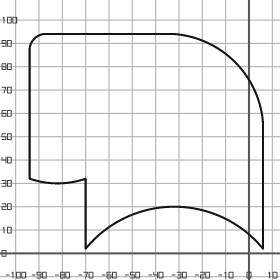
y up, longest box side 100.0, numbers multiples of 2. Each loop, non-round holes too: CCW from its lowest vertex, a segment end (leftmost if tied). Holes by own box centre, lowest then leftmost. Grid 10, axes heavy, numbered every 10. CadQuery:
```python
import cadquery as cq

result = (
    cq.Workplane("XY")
    .moveTo(-70.0, 2.0)
    .threePointArc((-32.0, 20.0), (6.0, 2.0))
    .lineTo(6.0, 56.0)
    .threePointArc((-6.0, 82.0), (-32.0, 94.0))
    .lineTo(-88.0, 94.0)
    .threePointArc((-92.0, 92.0), (-94.0, 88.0))
    .lineTo(-94.0, 32.0)
    .threePointArc((-82.0, 30.0), (-70.0, 32.0))
    .close()
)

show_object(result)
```